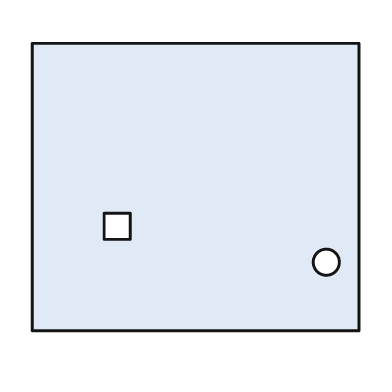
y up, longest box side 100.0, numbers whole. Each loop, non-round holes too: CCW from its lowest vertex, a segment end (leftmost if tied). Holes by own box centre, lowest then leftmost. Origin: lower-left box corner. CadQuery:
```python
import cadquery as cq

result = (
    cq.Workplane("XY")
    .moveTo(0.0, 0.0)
    .lineTo(100.0, 0.0)
    .lineTo(100.0, 88.0)
    .lineTo(0.0, 88.0)
    .close()
    .moveTo(90.0, 21.0)
    .circle(4.0)
    .moveTo(22.0, 28.0)
    .lineTo(30.0, 28.0)
    .lineTo(30.0, 36.0)
    .lineTo(22.0, 36.0)
    .close()
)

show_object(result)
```